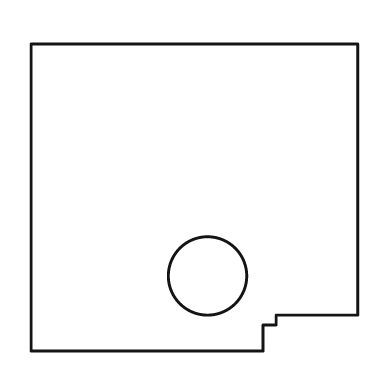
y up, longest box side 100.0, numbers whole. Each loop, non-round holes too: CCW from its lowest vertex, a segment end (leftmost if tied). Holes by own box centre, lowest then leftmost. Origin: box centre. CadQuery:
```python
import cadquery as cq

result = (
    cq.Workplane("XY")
    .moveTo(-50.0, -47.0)
    .lineTo(21.0, -47.0)
    .lineTo(21.0, -39.0)
    .lineTo(25.0, -39.0)
    .lineTo(25.0, -36.0)
    .lineTo(50.0, -36.0)
    .lineTo(50.0, 47.0)
    .lineTo(-50.0, 47.0)
    .close()
    .moveTo(4.0, -24.0)
    .circle(12.0)
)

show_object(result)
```